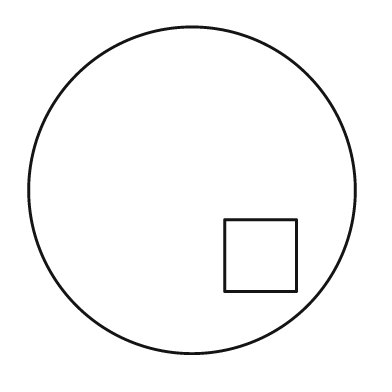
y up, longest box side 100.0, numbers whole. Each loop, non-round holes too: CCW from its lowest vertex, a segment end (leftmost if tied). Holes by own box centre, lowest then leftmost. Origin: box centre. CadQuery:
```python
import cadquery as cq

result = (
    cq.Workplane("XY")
    .moveTo(0.0, 0.0)
    .circle(50.0)
    .moveTo(10.0, -31.0)
    .lineTo(32.0, -31.0)
    .lineTo(32.0, -9.0)
    .lineTo(10.0, -9.0)
    .close()
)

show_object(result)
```